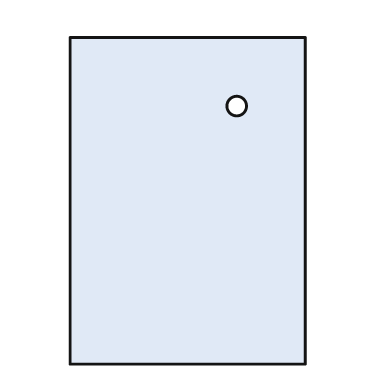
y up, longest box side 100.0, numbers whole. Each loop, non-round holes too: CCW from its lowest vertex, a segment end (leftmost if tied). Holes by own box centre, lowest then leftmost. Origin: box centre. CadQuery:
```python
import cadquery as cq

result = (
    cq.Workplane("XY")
    .moveTo(-36.0, -50.0)
    .lineTo(36.0, -50.0)
    .lineTo(36.0, 50.0)
    .lineTo(-36.0, 50.0)
    .close()
    .moveTo(15.0, 29.0)
    .circle(3.0)
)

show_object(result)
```